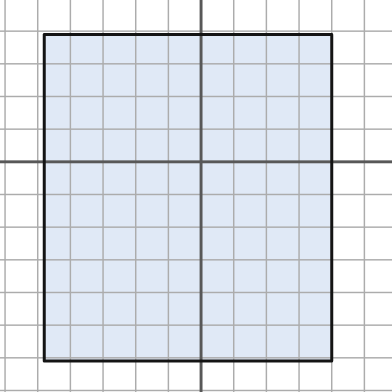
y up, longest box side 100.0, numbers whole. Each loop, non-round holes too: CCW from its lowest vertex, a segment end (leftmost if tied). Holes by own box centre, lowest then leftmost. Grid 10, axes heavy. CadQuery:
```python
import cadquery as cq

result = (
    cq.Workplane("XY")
    .moveTo(-48.0, -61.0)
    .lineTo(40.0, -61.0)
    .lineTo(40.0, 39.0)
    .lineTo(-48.0, 39.0)
    .close()
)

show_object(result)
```